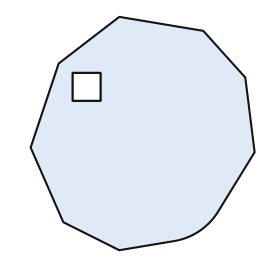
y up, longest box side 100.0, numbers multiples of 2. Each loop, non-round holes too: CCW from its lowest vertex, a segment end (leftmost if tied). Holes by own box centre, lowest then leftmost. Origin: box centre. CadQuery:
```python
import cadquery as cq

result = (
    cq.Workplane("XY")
    .moveTo(-10.0, -50.0)
    .lineTo(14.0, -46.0)
    .threePointArc((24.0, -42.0), (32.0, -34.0))
    .lineTo(48.0, -8.0)
    .lineTo(44.0, 24.0)
    .lineTo(26.0, 44.0)
    .lineTo(-10.0, 50.0)
    .lineTo(-36.0, 30.0)
    .lineTo(-48.0, -6.0)
    .lineTo(-34.0, -38.0)
    .close()
    .moveTo(-30.0, 14.0)
    .lineTo(-18.0, 14.0)
    .lineTo(-18.0, 26.0)
    .lineTo(-30.0, 26.0)
    .close()
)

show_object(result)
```